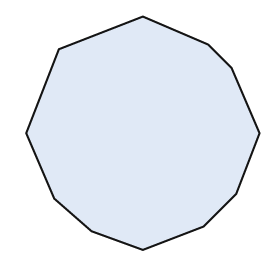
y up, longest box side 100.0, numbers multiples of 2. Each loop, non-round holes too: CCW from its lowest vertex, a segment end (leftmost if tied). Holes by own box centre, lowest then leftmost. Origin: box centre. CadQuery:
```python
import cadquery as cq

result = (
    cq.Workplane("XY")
    .moveTo(0.0, -50.0)
    .lineTo(26.0, -40.0)
    .lineTo(40.0, -26.0)
    .lineTo(50.0, 0.0)
    .lineTo(38.0, 28.0)
    .lineTo(28.0, 38.0)
    .lineTo(0.0, 50.0)
    .lineTo(-36.0, 36.0)
    .lineTo(-50.0, 0.0)
    .lineTo(-38.0, -28.0)
    .lineTo(-22.0, -42.0)
    .close()
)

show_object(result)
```